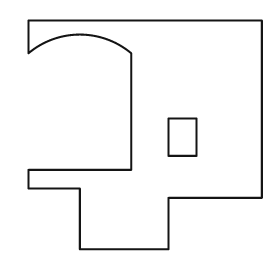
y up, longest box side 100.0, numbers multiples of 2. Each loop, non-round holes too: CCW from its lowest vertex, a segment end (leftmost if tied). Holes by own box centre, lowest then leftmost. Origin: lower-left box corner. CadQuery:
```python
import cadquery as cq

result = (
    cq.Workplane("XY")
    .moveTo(22.0, 0.0)
    .lineTo(60.0, 0.0)
    .lineTo(60.0, 22.0)
    .lineTo(100.0, 22.0)
    .lineTo(100.0, 98.0)
    .lineTo(0.0, 98.0)
    .lineTo(0.0, 84.0)
    .threePointArc((22.0, 92.0), (44.0, 84.0))
    .lineTo(44.0, 34.0)
    .lineTo(0.0, 34.0)
    .lineTo(0.0, 26.0)
    .lineTo(22.0, 26.0)
    .close()
    .moveTo(60.0, 40.0)
    .lineTo(72.0, 40.0)
    .lineTo(72.0, 56.0)
    .lineTo(60.0, 56.0)
    .close()
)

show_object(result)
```